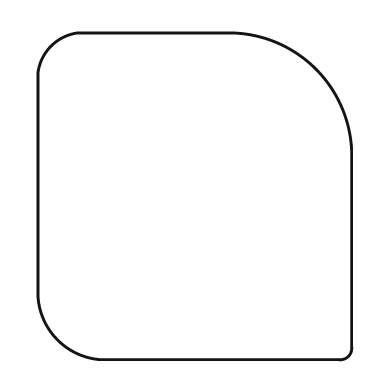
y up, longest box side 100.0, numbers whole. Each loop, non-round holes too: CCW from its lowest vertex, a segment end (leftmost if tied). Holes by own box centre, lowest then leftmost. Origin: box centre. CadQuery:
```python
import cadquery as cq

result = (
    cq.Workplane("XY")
    .moveTo(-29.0, -50.0)
    .lineTo(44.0, -50.0)
    .threePointArc((47.0, -49.0), (48.0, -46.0))
    .lineTo(48.0, 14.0)
    .threePointArc((37.0, 39.0), (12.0, 50.0))
    .lineTo(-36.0, 50.0)
    .threePointArc((-44.0, 46.0), (-48.0, 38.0))
    .lineTo(-48.0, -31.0)
    .threePointArc((-42.0, -44.0), (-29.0, -50.0))
    .close()
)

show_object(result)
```